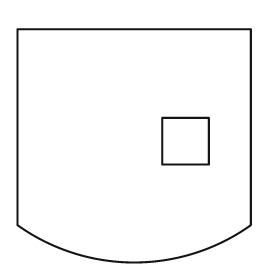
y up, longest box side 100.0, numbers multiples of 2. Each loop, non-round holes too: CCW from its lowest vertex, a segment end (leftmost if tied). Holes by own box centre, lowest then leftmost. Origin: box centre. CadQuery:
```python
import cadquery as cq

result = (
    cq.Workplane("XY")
    .moveTo(-50.0, -34.0)
    .threePointArc((0.0, -50.0), (50.0, -34.0))
    .lineTo(50.0, 50.0)
    .lineTo(-50.0, 50.0)
    .close()
    .moveTo(12.0, -8.0)
    .lineTo(32.0, -8.0)
    .lineTo(32.0, 12.0)
    .lineTo(12.0, 12.0)
    .close()
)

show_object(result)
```